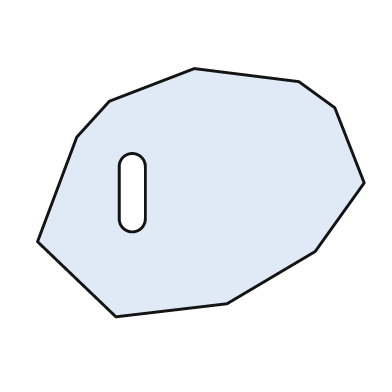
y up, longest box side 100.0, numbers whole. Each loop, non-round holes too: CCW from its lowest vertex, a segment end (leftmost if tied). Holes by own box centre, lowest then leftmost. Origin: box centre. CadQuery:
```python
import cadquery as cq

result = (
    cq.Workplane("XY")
    .moveTo(-26.0, -38.0)
    .lineTo(8.0, -34.0)
    .lineTo(35.0, -18.0)
    .lineTo(50.0, 3.0)
    .lineTo(41.0, 26.0)
    .lineTo(30.0, 34.0)
    .lineTo(-2.0, 38.0)
    .lineTo(-28.0, 28.0)
    .lineTo(-38.0, 17.0)
    .lineTo(-50.0, -15.0)
    .close()
    .moveTo(-25.0, -8.0)
    .threePointArc((-21.0, -12.0), (-17.0, -8.0))
    .lineTo(-17.0, 8.0)
    .threePointArc((-21.0, 12.0), (-25.0, 8.0))
    .close()
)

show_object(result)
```